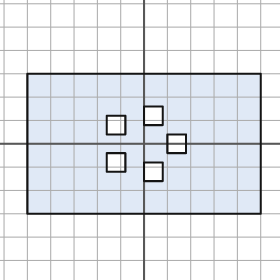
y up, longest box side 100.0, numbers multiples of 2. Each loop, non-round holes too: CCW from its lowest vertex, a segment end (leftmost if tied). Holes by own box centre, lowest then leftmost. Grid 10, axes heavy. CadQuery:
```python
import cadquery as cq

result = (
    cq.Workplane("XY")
    .moveTo(-50.0, -30.0)
    .lineTo(50.0, -30.0)
    .lineTo(50.0, 30.0)
    .lineTo(-50.0, 30.0)
    .close()
    .moveTo(0.0, -16.0)
    .lineTo(8.0, -16.0)
    .lineTo(8.0, -8.0)
    .lineTo(0.0, -8.0)
    .close()
    .moveTo(-16.0, -12.0)
    .lineTo(-8.0, -12.0)
    .lineTo(-8.0, -4.0)
    .lineTo(-16.0, -4.0)
    .close()
    .moveTo(10.0, -4.0)
    .lineTo(18.0, -4.0)
    .lineTo(18.0, 4.0)
    .lineTo(10.0, 4.0)
    .close()
    .moveTo(-16.0, 4.0)
    .lineTo(-8.0, 4.0)
    .lineTo(-8.0, 12.0)
    .lineTo(-16.0, 12.0)
    .close()
    .moveTo(0.0, 8.0)
    .lineTo(8.0, 8.0)
    .lineTo(8.0, 16.0)
    .lineTo(0.0, 16.0)
    .close()
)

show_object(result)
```